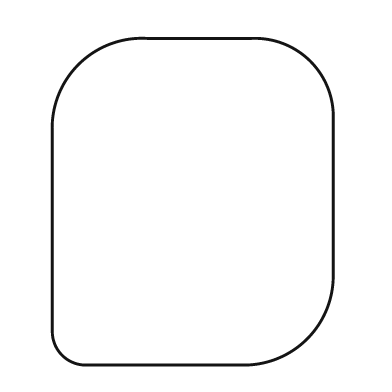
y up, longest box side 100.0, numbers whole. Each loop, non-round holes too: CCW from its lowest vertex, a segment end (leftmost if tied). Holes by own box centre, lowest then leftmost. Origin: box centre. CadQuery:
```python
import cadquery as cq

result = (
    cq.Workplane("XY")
    .moveTo(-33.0, -50.0)
    .lineTo(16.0, -50.0)
    .threePointArc((35.0, -42.0), (43.0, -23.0))
    .lineTo(43.0, 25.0)
    .threePointArc((36.0, 43.0), (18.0, 50.0))
    .lineTo(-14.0, 50.0)
    .threePointArc((-35.0, 42.0), (-43.0, 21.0))
    .lineTo(-43.0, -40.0)
    .threePointArc((-40.0, -47.0), (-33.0, -50.0))
    .close()
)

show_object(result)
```